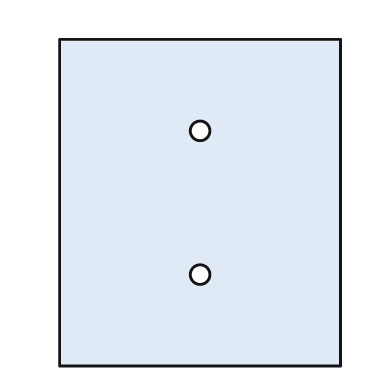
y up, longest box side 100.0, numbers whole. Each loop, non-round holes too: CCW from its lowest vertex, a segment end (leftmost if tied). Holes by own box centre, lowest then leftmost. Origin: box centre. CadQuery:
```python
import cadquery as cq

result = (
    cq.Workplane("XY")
    .moveTo(-43.0, -50.0)
    .lineTo(43.0, -50.0)
    .lineTo(43.0, 50.0)
    .lineTo(-43.0, 50.0)
    .close()
    .moveTo(0.0, -22.0)
    .circle(3.0)
    .moveTo(0.0, 22.0)
    .circle(3.0)
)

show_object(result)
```